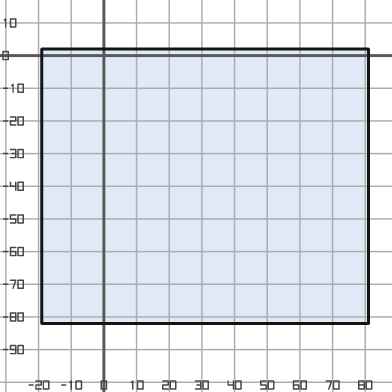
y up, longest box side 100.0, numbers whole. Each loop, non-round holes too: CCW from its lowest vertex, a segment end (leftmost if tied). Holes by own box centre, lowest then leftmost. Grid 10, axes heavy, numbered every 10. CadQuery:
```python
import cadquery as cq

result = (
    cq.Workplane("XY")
    .moveTo(-19.0, -82.0)
    .lineTo(81.0, -82.0)
    .lineTo(81.0, 2.0)
    .lineTo(-19.0, 2.0)
    .close()
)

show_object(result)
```